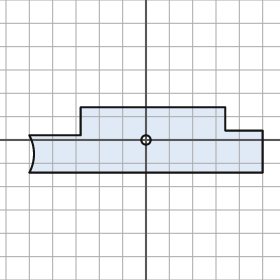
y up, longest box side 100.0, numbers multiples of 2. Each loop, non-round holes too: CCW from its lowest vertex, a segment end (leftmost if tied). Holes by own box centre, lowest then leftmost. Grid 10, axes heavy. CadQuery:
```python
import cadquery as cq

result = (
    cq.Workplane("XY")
    .moveTo(-50.0, -14.0)
    .lineTo(50.0, -14.0)
    .lineTo(50.0, 4.0)
    .lineTo(34.0, 4.0)
    .lineTo(34.0, 14.0)
    .lineTo(-28.0, 14.0)
    .lineTo(-28.0, 2.0)
    .lineTo(-50.0, 2.0)
    .threePointArc((-48.0, -6.0), (-50.0, -14.0))
    .close()
    .moveTo(0.0, 0.0)
    .circle(2.0)
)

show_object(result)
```